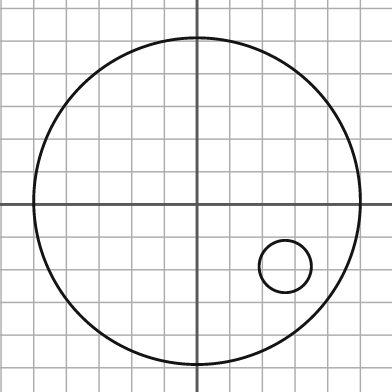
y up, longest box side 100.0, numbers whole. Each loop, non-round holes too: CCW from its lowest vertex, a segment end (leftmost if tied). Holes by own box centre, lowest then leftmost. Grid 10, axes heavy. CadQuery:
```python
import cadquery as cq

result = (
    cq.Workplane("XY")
    .moveTo(0.0, 1.0)
    .circle(50.0)
    .moveTo(27.0, -19.0)
    .circle(8.0)
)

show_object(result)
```